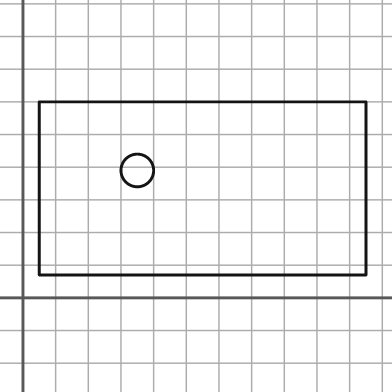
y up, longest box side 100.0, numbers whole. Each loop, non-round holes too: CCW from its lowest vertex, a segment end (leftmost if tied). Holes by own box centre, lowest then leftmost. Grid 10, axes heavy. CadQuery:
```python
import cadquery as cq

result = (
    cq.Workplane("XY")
    .moveTo(5.0, 7.0)
    .lineTo(105.0, 7.0)
    .lineTo(105.0, 60.0)
    .lineTo(5.0, 60.0)
    .close()
    .moveTo(35.0, 39.0)
    .circle(5.0)
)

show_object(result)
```